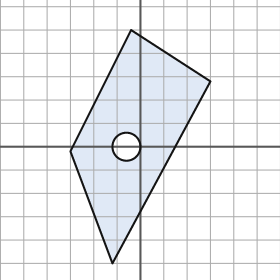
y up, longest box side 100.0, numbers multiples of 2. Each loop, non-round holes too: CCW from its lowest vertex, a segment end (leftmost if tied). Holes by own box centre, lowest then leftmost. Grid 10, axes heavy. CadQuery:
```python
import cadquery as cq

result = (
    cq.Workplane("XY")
    .moveTo(-12.0, -50.0)
    .lineTo(30.0, 28.0)
    .lineTo(-4.0, 50.0)
    .lineTo(-30.0, -2.0)
    .close()
    .moveTo(-6.0, 0.0)
    .circle(6.0)
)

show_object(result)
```